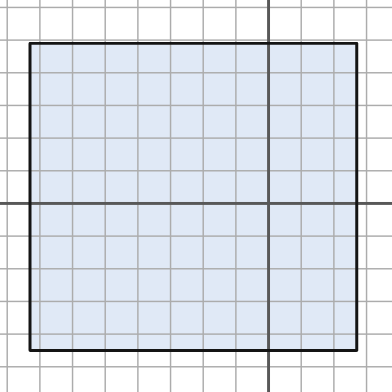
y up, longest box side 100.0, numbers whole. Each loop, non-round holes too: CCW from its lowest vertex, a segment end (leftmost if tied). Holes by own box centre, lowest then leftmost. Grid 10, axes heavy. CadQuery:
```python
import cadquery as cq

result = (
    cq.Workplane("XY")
    .moveTo(-73.0, -45.0)
    .lineTo(27.0, -45.0)
    .lineTo(27.0, 49.0)
    .lineTo(-73.0, 49.0)
    .close()
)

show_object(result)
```